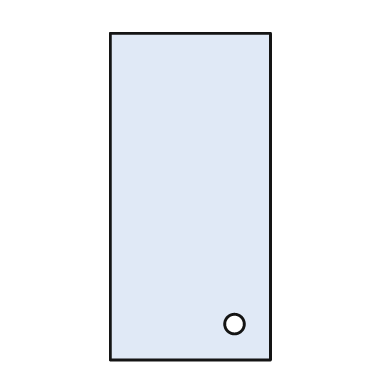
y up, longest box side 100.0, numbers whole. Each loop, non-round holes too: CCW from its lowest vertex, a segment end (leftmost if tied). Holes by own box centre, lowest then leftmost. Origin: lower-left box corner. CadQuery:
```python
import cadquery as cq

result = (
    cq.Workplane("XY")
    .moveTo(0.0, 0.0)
    .lineTo(49.0, 0.0)
    .lineTo(49.0, 100.0)
    .lineTo(0.0, 100.0)
    .close()
    .moveTo(38.0, 11.0)
    .circle(3.0)
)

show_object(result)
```